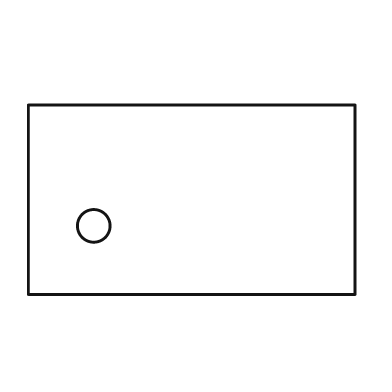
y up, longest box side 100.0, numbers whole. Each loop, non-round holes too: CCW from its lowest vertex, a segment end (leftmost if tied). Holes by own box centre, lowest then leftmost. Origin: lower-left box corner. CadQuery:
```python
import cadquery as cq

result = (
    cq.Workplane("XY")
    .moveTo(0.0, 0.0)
    .lineTo(100.0, 0.0)
    .lineTo(100.0, 58.0)
    .lineTo(0.0, 58.0)
    .close()
    .moveTo(20.0, 21.0)
    .circle(5.0)
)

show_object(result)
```